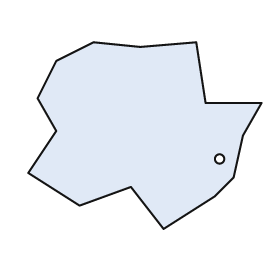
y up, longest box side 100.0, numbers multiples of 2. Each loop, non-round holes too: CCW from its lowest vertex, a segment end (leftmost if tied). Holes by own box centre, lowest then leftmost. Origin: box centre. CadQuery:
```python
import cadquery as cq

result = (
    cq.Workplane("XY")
    .moveTo(8.0, -40.0)
    .lineTo(30.0, -26.0)
    .lineTo(38.0, -18.0)
    .lineTo(42.0, 0.0)
    .lineTo(50.0, 14.0)
    .lineTo(26.0, 14.0)
    .lineTo(22.0, 40.0)
    .lineTo(-2.0, 38.0)
    .lineTo(-22.0, 40.0)
    .lineTo(-38.0, 32.0)
    .lineTo(-46.0, 16.0)
    .lineTo(-38.0, 2.0)
    .lineTo(-50.0, -16.0)
    .lineTo(-28.0, -30.0)
    .lineTo(-6.0, -22.0)
    .close()
    .moveTo(32.0, -10.0)
    .circle(2.0)
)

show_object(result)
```